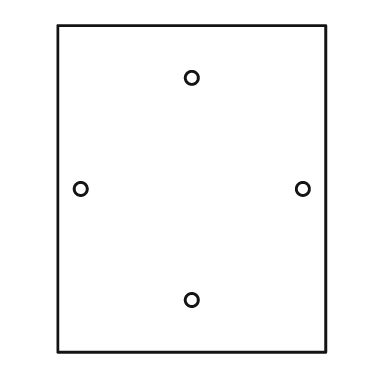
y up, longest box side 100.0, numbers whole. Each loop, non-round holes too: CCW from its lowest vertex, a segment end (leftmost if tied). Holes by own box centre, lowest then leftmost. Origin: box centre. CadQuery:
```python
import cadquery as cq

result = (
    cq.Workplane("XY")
    .moveTo(-41.0, -50.0)
    .lineTo(41.0, -50.0)
    .lineTo(41.0, 50.0)
    .lineTo(-41.0, 50.0)
    .close()
    .moveTo(0.0, -34.0)
    .circle(2.0)
    .moveTo(-34.0, 0.0)
    .circle(2.0)
    .moveTo(34.0, 0.0)
    .circle(2.0)
    .moveTo(0.0, 34.0)
    .circle(2.0)
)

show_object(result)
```